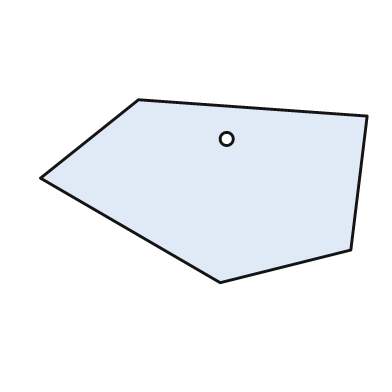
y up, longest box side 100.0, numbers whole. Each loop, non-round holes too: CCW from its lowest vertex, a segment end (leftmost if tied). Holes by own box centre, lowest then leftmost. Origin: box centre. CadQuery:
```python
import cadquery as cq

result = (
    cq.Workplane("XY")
    .moveTo(5.0, -28.0)
    .lineTo(45.0, -18.0)
    .lineTo(50.0, 23.0)
    .lineTo(-20.0, 28.0)
    .lineTo(-50.0, 4.0)
    .close()
    .moveTo(7.0, 16.0)
    .circle(2.0)
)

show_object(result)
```